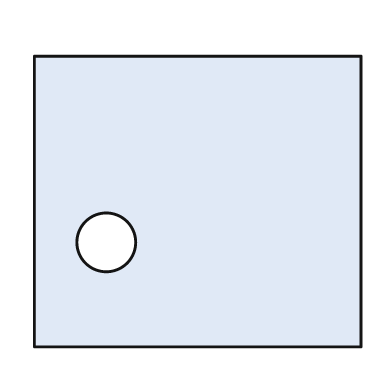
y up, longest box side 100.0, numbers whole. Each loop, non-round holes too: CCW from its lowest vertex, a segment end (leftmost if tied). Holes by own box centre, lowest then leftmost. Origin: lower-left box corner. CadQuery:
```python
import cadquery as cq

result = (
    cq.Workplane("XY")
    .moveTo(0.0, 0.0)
    .lineTo(100.0, 0.0)
    .lineTo(100.0, 89.0)
    .lineTo(0.0, 89.0)
    .close()
    .moveTo(22.0, 32.0)
    .circle(9.0)
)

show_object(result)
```